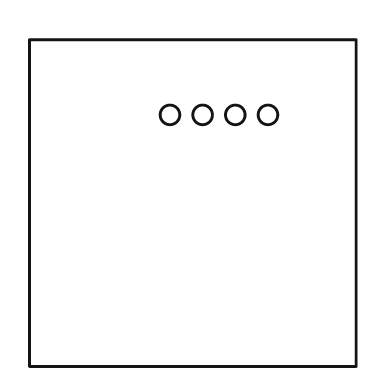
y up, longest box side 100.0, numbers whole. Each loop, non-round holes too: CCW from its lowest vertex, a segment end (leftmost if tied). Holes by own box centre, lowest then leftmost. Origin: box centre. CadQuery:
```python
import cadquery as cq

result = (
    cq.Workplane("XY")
    .moveTo(-50.0, -50.0)
    .lineTo(50.0, -50.0)
    .lineTo(50.0, 50.0)
    .lineTo(-50.0, 50.0)
    .close()
    .moveTo(-7.0, 27.0)
    .circle(3.0)
    .moveTo(3.0, 27.0)
    .circle(3.0)
    .moveTo(13.0, 27.0)
    .circle(3.0)
    .moveTo(23.0, 27.0)
    .circle(3.0)
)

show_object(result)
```